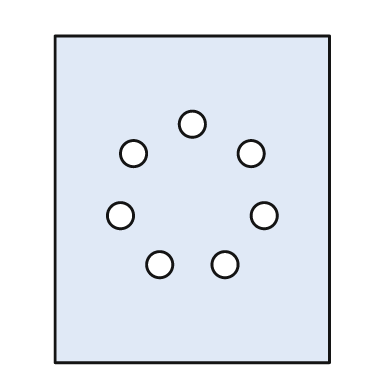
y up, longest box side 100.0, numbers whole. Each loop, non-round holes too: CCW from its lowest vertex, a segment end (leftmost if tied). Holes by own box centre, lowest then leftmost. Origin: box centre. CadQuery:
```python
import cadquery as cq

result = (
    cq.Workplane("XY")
    .moveTo(-42.0, -50.0)
    .lineTo(42.0, -50.0)
    .lineTo(42.0, 50.0)
    .lineTo(-42.0, 50.0)
    .close()
    .moveTo(-10.0, -20.0)
    .circle(4.0)
    .moveTo(10.0, -20.0)
    .circle(4.0)
    .moveTo(-22.0, -5.0)
    .circle(4.0)
    .moveTo(22.0, -5.0)
    .circle(4.0)
    .moveTo(-18.0, 14.0)
    .circle(4.0)
    .moveTo(18.0, 14.0)
    .circle(4.0)
    .moveTo(0.0, 23.0)
    .circle(4.0)
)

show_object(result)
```